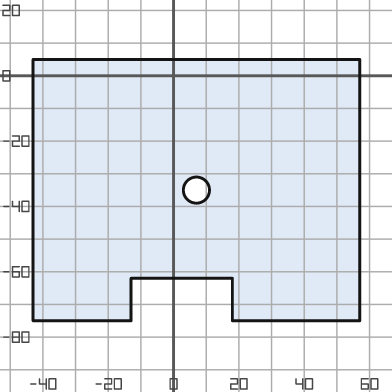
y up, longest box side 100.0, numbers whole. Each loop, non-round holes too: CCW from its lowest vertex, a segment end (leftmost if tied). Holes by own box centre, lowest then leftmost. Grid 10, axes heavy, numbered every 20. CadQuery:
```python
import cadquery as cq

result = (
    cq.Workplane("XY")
    .moveTo(-43.0, -75.0)
    .lineTo(-13.0, -75.0)
    .lineTo(-13.0, -62.0)
    .lineTo(18.0, -62.0)
    .lineTo(18.0, -75.0)
    .lineTo(57.0, -75.0)
    .lineTo(57.0, 5.0)
    .lineTo(-43.0, 5.0)
    .close()
    .moveTo(7.0, -35.0)
    .circle(4.0)
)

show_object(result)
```